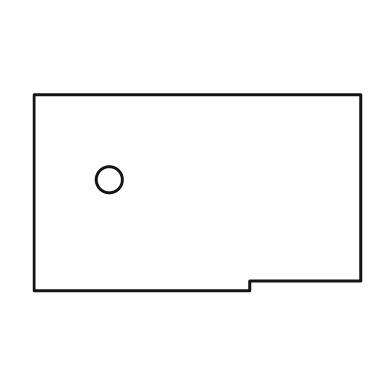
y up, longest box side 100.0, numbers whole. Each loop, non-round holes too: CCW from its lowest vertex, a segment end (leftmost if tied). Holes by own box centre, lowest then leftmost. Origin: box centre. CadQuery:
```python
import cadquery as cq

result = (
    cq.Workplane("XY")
    .moveTo(-50.0, -30.0)
    .lineTo(16.0, -30.0)
    .lineTo(16.0, -27.0)
    .lineTo(50.0, -27.0)
    .lineTo(50.0, 30.0)
    .lineTo(-50.0, 30.0)
    .close()
    .moveTo(-27.0, 4.0)
    .circle(4.0)
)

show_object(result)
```